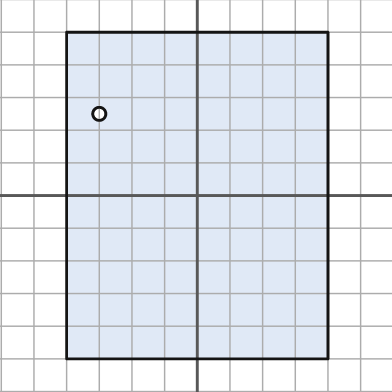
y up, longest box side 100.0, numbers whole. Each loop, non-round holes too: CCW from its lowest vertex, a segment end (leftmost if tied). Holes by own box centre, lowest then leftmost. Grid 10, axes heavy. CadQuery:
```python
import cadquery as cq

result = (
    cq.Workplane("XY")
    .moveTo(-40.0, -50.0)
    .lineTo(40.0, -50.0)
    .lineTo(40.0, 50.0)
    .lineTo(-40.0, 50.0)
    .close()
    .moveTo(-30.0, 25.0)
    .circle(2.0)
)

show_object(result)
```